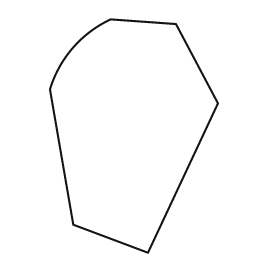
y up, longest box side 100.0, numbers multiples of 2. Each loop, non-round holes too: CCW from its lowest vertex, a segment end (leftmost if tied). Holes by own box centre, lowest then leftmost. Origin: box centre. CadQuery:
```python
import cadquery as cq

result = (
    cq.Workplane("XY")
    .moveTo(6.0, -50.0)
    .lineTo(36.0, 14.0)
    .lineTo(18.0, 48.0)
    .lineTo(-10.0, 50.0)
    .threePointArc((-26.0, 38.0), (-36.0, 20.0))
    .lineTo(-26.0, -38.0)
    .close()
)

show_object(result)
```